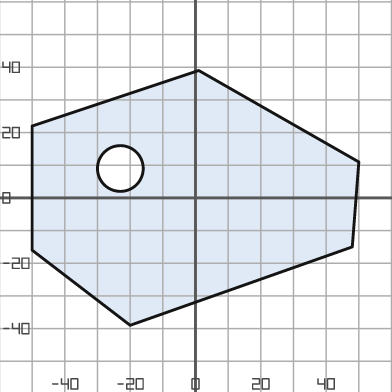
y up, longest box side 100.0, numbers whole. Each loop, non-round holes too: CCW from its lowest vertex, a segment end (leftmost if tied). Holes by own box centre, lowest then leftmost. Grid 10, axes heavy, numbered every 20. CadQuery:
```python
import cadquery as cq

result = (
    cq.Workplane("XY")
    .moveTo(-20.0, -39.0)
    .lineTo(48.0, -15.0)
    .lineTo(50.0, 11.0)
    .lineTo(1.0, 39.0)
    .lineTo(-50.0, 22.0)
    .lineTo(-50.0, -16.0)
    .close()
    .moveTo(-23.0, 9.0)
    .circle(7.0)
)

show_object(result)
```